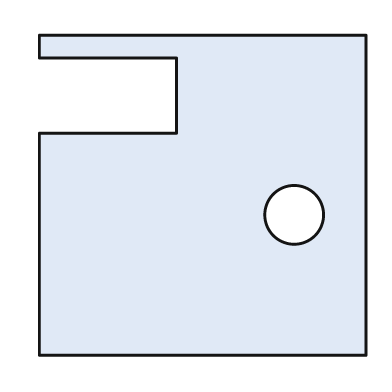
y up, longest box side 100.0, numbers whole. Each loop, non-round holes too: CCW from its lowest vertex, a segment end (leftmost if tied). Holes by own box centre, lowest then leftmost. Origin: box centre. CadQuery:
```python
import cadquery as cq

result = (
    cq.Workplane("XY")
    .moveTo(-50.0, -49.0)
    .lineTo(50.0, -49.0)
    .lineTo(50.0, 49.0)
    .lineTo(-50.0, 49.0)
    .lineTo(-50.0, 42.0)
    .lineTo(-8.0, 42.0)
    .lineTo(-8.0, 19.0)
    .lineTo(-50.0, 19.0)
    .close()
    .moveTo(28.0, -6.0)
    .circle(9.0)
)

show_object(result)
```